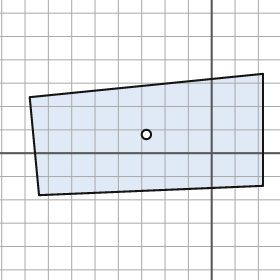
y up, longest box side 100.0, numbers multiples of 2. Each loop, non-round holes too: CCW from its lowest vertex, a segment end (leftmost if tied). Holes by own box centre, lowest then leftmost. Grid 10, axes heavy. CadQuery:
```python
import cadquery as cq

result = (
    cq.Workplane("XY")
    .moveTo(-74.0, -18.0)
    .lineTo(22.0, -14.0)
    .lineTo(22.0, 34.0)
    .lineTo(-78.0, 24.0)
    .close()
    .moveTo(-28.0, 8.0)
    .circle(2.0)
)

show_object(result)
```